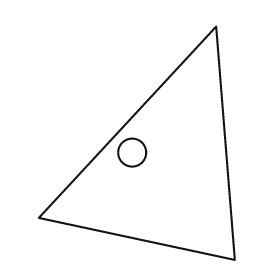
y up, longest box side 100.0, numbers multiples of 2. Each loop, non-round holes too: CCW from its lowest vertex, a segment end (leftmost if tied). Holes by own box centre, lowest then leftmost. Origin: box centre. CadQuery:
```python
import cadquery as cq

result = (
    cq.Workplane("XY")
    .moveTo(42.0, -50.0)
    .lineTo(34.0, 50.0)
    .lineTo(-42.0, -32.0)
    .close()
    .moveTo(-2.0, -4.0)
    .circle(6.0)
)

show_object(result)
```